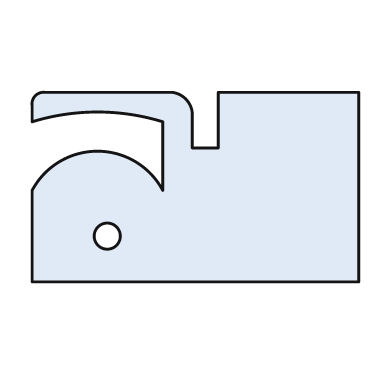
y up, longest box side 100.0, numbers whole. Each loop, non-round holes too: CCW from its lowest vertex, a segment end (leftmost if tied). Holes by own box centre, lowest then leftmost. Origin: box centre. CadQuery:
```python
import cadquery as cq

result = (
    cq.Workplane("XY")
    .moveTo(-50.0, -29.0)
    .lineTo(50.0, -29.0)
    .lineTo(50.0, 29.0)
    .lineTo(7.0, 29.0)
    .lineTo(7.0, 12.0)
    .lineTo(-1.0, 12.0)
    .lineTo(-1.0, 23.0)
    .threePointArc((-3.0, 27.0), (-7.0, 29.0))
    .lineTo(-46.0, 29.0)
    .threePointArc((-49.0, 28.0), (-50.0, 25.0))
    .lineTo(-50.0, 20.0)
    .threePointArc((-30.0, 23.0), (-10.0, 20.0))
    .lineTo(-10.0, -1.0)
    .threePointArc((-30.0, 11.0), (-50.0, -1.0))
    .close()
    .moveTo(-27.0, -15.0)
    .circle(4.0)
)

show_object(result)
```